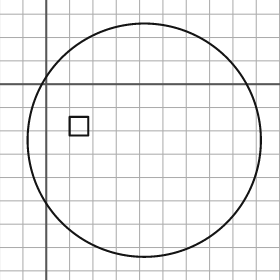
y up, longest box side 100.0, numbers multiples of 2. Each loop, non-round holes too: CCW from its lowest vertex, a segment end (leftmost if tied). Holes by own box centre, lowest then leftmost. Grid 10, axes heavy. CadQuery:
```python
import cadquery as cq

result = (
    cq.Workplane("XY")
    .moveTo(42.0, -24.0)
    .circle(50.0)
    .moveTo(10.0, -22.0)
    .lineTo(18.0, -22.0)
    .lineTo(18.0, -14.0)
    .lineTo(10.0, -14.0)
    .close()
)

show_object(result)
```